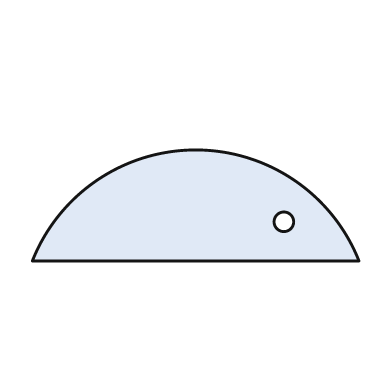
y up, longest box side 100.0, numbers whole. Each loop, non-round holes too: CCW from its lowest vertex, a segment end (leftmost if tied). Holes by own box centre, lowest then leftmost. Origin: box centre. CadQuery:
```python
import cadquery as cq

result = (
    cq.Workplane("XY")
    .moveTo(-50.0, -17.0)
    .lineTo(50.0, -17.0)
    .threePointArc((0.0, 17.0), (-50.0, -17.0))
    .close()
    .moveTo(27.0, -5.0)
    .circle(3.0)
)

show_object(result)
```